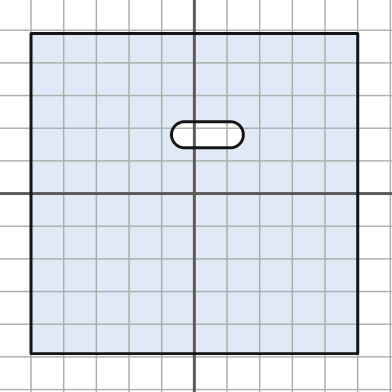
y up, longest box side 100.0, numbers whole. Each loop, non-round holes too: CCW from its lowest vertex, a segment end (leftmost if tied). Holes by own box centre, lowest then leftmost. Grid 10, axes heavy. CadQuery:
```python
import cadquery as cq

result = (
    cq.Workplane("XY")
    .moveTo(-50.0, -49.0)
    .lineTo(50.0, -49.0)
    .lineTo(50.0, 49.0)
    .lineTo(-50.0, 49.0)
    .close()
    .moveTo(-3.0, 14.0)
    .lineTo(11.0, 14.0)
    .threePointArc((15.0, 18.0), (11.0, 22.0))
    .lineTo(-3.0, 22.0)
    .threePointArc((-7.0, 18.0), (-3.0, 14.0))
    .close()
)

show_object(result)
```